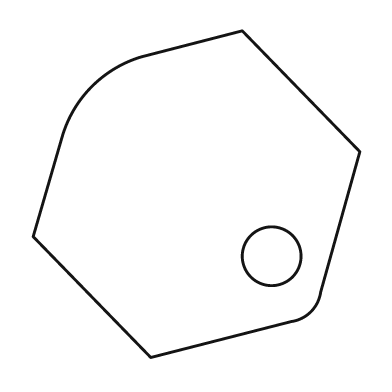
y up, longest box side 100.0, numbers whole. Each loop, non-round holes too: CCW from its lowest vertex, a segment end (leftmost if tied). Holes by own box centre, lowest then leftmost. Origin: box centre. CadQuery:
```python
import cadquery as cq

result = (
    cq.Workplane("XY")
    .moveTo(-14.0, -50.0)
    .lineTo(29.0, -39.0)
    .threePointArc((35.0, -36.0), (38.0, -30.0))
    .lineTo(50.0, 13.0)
    .lineTo(14.0, 50.0)
    .lineTo(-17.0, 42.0)
    .threePointArc((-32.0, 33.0), (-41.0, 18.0))
    .lineTo(-50.0, -13.0)
    .close()
    .moveTo(23.0, -19.0)
    .circle(9.0)
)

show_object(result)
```